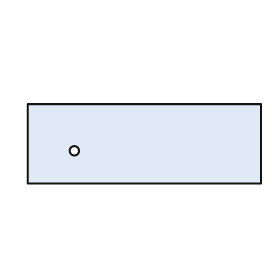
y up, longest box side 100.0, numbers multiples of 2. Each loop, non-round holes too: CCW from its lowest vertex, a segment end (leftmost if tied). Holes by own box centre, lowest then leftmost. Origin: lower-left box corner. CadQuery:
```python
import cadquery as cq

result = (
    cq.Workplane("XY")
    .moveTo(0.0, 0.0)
    .lineTo(100.0, 0.0)
    .lineTo(100.0, 34.0)
    .lineTo(0.0, 34.0)
    .close()
    .moveTo(20.0, 14.0)
    .circle(2.0)
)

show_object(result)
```